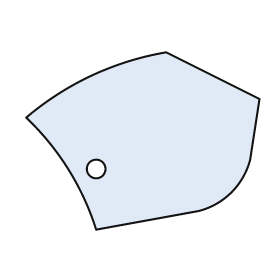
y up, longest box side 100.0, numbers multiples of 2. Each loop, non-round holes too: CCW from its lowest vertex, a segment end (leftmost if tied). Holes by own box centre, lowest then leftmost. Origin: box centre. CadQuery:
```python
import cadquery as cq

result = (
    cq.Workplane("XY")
    .moveTo(-20.0, -38.0)
    .lineTo(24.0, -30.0)
    .threePointArc((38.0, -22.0), (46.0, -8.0))
    .lineTo(50.0, 18.0)
    .lineTo(10.0, 38.0)
    .threePointArc((-22.0, 28.0), (-50.0, 10.0))
    .threePointArc((-32.0, -12.0), (-20.0, -38.0))
    .close()
    .moveTo(-20.0, -12.0)
    .circle(4.0)
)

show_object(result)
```